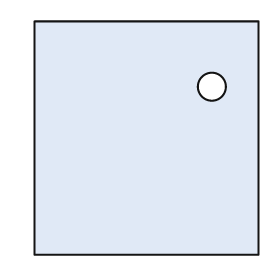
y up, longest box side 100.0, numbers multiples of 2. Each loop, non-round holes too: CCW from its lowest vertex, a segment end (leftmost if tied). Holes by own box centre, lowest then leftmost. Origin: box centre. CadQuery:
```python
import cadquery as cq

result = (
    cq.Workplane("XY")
    .moveTo(-48.0, -50.0)
    .lineTo(48.0, -50.0)
    .lineTo(48.0, 50.0)
    .lineTo(-48.0, 50.0)
    .close()
    .moveTo(28.0, 22.0)
    .circle(6.0)
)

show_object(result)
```